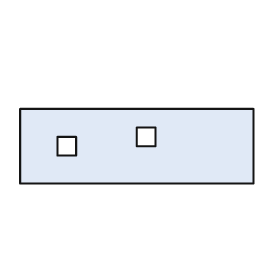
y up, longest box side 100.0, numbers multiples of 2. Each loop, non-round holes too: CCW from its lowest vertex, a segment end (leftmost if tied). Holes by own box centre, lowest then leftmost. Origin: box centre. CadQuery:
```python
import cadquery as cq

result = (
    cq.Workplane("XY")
    .moveTo(-50.0, -16.0)
    .lineTo(50.0, -16.0)
    .lineTo(50.0, 16.0)
    .lineTo(-50.0, 16.0)
    .close()
    .moveTo(-34.0, -4.0)
    .lineTo(-26.0, -4.0)
    .lineTo(-26.0, 4.0)
    .lineTo(-34.0, 4.0)
    .close()
    .moveTo(0.0, 0.0)
    .lineTo(8.0, 0.0)
    .lineTo(8.0, 8.0)
    .lineTo(0.0, 8.0)
    .close()
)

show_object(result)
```